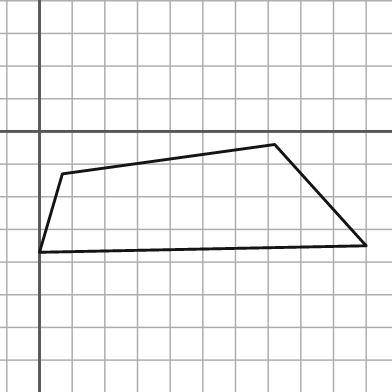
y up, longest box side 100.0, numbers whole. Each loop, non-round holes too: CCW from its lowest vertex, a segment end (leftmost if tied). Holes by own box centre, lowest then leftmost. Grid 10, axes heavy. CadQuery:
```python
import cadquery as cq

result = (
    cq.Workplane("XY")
    .moveTo(0.0, -37.0)
    .lineTo(100.0, -35.0)
    .lineTo(72.0, -4.0)
    .lineTo(7.0, -13.0)
    .close()
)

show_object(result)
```